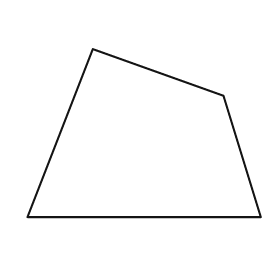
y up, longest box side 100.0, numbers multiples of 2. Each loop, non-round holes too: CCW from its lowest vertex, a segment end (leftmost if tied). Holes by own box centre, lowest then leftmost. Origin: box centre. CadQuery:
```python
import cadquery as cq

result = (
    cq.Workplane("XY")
    .moveTo(-50.0, -36.0)
    .lineTo(50.0, -36.0)
    .lineTo(34.0, 16.0)
    .lineTo(-22.0, 36.0)
    .close()
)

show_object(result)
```